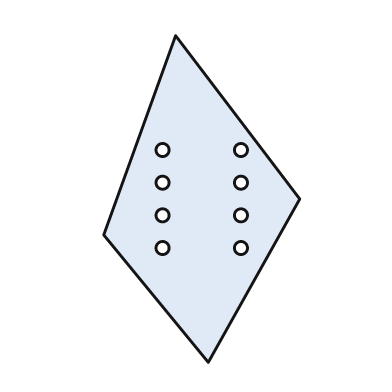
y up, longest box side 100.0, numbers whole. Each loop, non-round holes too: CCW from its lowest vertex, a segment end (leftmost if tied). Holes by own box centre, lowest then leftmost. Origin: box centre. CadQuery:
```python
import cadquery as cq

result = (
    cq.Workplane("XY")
    .moveTo(2.0, -50.0)
    .lineTo(30.0, 0.0)
    .lineTo(-8.0, 50.0)
    .lineTo(-30.0, -11.0)
    .close()
    .moveTo(-12.0, -15.0)
    .circle(2.0)
    .moveTo(12.0, -15.0)
    .circle(2.0)
    .moveTo(-12.0, -5.0)
    .circle(2.0)
    .moveTo(12.0, -5.0)
    .circle(2.0)
    .moveTo(-12.0, 5.0)
    .circle(2.0)
    .moveTo(12.0, 5.0)
    .circle(2.0)
    .moveTo(-12.0, 15.0)
    .circle(2.0)
    .moveTo(12.0, 15.0)
    .circle(2.0)
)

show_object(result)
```